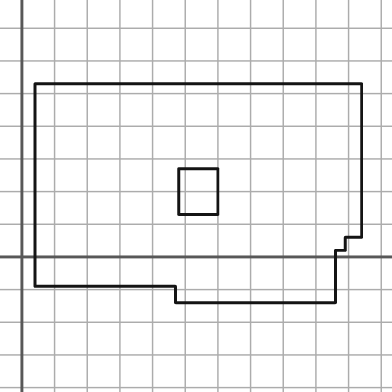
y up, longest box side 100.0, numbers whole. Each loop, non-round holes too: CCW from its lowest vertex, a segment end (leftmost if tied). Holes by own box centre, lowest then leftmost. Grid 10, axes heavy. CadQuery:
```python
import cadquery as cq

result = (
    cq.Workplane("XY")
    .moveTo(47.0, -14.0)
    .lineTo(96.0, -14.0)
    .lineTo(96.0, 2.0)
    .lineTo(99.0, 2.0)
    .lineTo(99.0, 6.0)
    .lineTo(104.0, 6.0)
    .lineTo(104.0, 53.0)
    .lineTo(4.0, 53.0)
    .lineTo(4.0, -9.0)
    .lineTo(47.0, -9.0)
    .close()
    .moveTo(48.0, 13.0)
    .lineTo(60.0, 13.0)
    .lineTo(60.0, 27.0)
    .lineTo(48.0, 27.0)
    .close()
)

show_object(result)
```